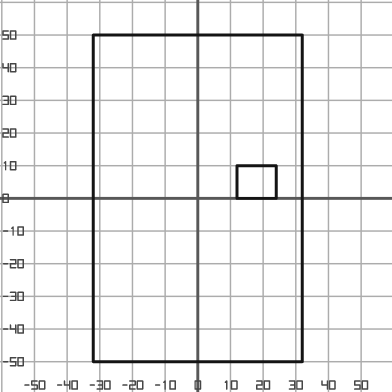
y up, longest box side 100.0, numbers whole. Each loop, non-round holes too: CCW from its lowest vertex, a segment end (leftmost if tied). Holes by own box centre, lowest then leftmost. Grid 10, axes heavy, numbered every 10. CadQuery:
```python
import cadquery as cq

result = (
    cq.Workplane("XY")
    .moveTo(-32.0, -50.0)
    .lineTo(32.0, -50.0)
    .lineTo(32.0, 50.0)
    .lineTo(-32.0, 50.0)
    .close()
    .moveTo(12.0, 0.0)
    .lineTo(24.0, 0.0)
    .lineTo(24.0, 10.0)
    .lineTo(12.0, 10.0)
    .close()
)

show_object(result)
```